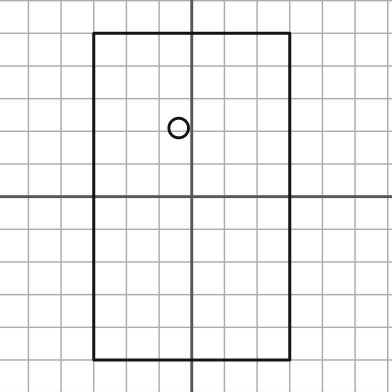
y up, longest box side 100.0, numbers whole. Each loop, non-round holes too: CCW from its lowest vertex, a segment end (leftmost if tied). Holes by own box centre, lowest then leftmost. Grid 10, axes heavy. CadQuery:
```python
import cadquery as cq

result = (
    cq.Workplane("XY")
    .moveTo(-30.0, -50.0)
    .lineTo(30.0, -50.0)
    .lineTo(30.0, 50.0)
    .lineTo(-30.0, 50.0)
    .close()
    .moveTo(-4.0, 21.0)
    .circle(3.0)
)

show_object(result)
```